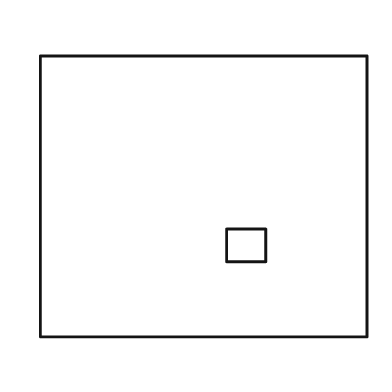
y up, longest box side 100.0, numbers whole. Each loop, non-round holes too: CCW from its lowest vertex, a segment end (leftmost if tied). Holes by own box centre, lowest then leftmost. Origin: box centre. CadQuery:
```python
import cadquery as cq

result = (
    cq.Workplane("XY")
    .moveTo(-50.0, -43.0)
    .lineTo(50.0, -43.0)
    .lineTo(50.0, 43.0)
    .lineTo(-50.0, 43.0)
    .close()
    .moveTo(7.0, -20.0)
    .lineTo(19.0, -20.0)
    .lineTo(19.0, -10.0)
    .lineTo(7.0, -10.0)
    .close()
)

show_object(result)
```